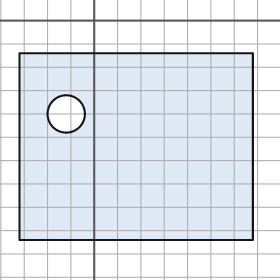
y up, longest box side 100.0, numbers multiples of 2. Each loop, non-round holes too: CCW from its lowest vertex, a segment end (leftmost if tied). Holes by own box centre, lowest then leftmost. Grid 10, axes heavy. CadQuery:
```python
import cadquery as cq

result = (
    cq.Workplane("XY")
    .moveTo(-32.0, -94.0)
    .lineTo(68.0, -94.0)
    .lineTo(68.0, -14.0)
    .lineTo(-32.0, -14.0)
    .close()
    .moveTo(-12.0, -40.0)
    .circle(8.0)
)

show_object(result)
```